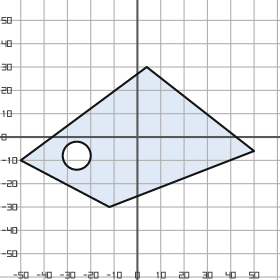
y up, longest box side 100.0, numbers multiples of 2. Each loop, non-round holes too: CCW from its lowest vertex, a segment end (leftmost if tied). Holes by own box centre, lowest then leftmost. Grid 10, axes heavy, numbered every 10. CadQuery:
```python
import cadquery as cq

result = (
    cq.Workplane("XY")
    .moveTo(-12.0, -30.0)
    .lineTo(50.0, -6.0)
    .lineTo(4.0, 30.0)
    .lineTo(-50.0, -10.0)
    .close()
    .moveTo(-26.0, -8.0)
    .circle(6.0)
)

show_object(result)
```